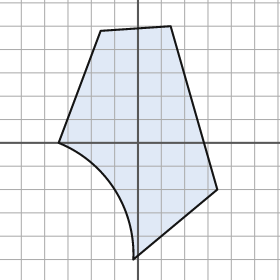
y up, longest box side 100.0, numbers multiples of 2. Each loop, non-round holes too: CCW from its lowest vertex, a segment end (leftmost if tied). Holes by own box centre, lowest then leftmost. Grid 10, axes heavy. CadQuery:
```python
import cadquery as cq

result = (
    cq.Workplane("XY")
    .moveTo(-2.0, -50.0)
    .lineTo(34.0, -20.0)
    .lineTo(14.0, 50.0)
    .lineTo(-16.0, 48.0)
    .lineTo(-34.0, 0.0)
    .threePointArc((-10.0, -20.0), (-2.0, -50.0))
    .close()
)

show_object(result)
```